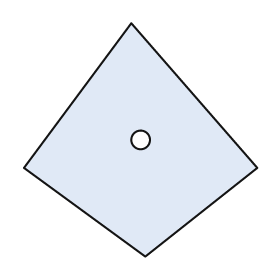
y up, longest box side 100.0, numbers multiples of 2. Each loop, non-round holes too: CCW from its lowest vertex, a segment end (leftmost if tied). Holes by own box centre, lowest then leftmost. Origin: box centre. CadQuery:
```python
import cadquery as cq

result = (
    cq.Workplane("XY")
    .moveTo(2.0, -50.0)
    .lineTo(50.0, -12.0)
    .lineTo(-4.0, 50.0)
    .lineTo(-50.0, -12.0)
    .close()
    .moveTo(0.0, 0.0)
    .circle(4.0)
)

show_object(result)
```